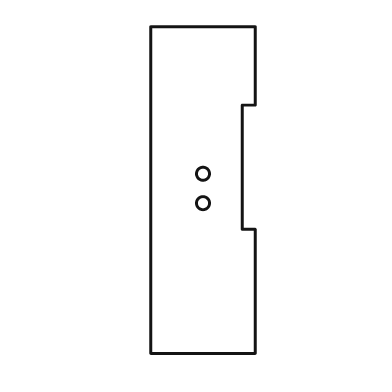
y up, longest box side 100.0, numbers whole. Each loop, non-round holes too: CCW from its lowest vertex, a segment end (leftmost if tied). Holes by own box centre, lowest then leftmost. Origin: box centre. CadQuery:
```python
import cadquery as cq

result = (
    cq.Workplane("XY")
    .moveTo(-16.0, -50.0)
    .lineTo(16.0, -50.0)
    .lineTo(16.0, -12.0)
    .lineTo(12.0, -12.0)
    .lineTo(12.0, 26.0)
    .lineTo(16.0, 26.0)
    .lineTo(16.0, 50.0)
    .lineTo(-16.0, 50.0)
    .close()
    .moveTo(0.0, -4.0)
    .circle(2.0)
    .moveTo(0.0, 5.0)
    .circle(2.0)
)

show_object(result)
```